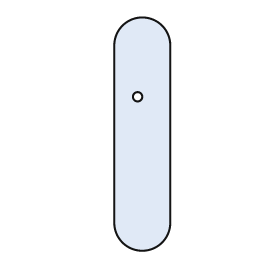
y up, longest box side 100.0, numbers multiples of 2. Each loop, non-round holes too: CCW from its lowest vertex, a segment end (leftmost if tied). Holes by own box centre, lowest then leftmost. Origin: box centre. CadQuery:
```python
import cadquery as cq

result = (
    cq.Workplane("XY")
    .moveTo(-12.0, -38.0)
    .threePointArc((0.0, -50.0), (12.0, -38.0))
    .lineTo(12.0, 38.0)
    .threePointArc((0.0, 50.0), (-12.0, 38.0))
    .close()
    .moveTo(-2.0, 16.0)
    .circle(2.0)
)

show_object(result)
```